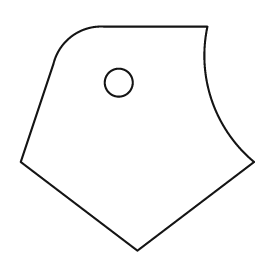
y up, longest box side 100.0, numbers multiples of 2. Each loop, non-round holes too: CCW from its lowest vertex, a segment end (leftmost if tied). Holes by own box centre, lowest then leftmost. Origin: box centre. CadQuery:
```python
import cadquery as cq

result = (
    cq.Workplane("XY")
    .moveTo(0.0, -48.0)
    .lineTo(50.0, -10.0)
    .threePointArc((32.0, 16.0), (30.0, 48.0))
    .lineTo(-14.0, 48.0)
    .threePointArc((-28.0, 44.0), (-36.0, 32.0))
    .lineTo(-50.0, -10.0)
    .close()
    .moveTo(-8.0, 24.0)
    .circle(6.0)
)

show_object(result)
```